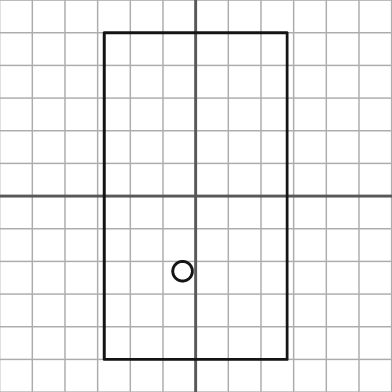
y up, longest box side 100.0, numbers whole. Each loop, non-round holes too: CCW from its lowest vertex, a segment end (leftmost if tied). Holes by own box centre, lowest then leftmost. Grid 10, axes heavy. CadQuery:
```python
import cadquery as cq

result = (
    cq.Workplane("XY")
    .moveTo(-28.0, -50.0)
    .lineTo(28.0, -50.0)
    .lineTo(28.0, 50.0)
    .lineTo(-28.0, 50.0)
    .close()
    .moveTo(-4.0, -23.0)
    .circle(3.0)
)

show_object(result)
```